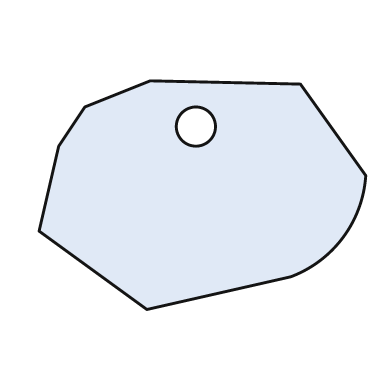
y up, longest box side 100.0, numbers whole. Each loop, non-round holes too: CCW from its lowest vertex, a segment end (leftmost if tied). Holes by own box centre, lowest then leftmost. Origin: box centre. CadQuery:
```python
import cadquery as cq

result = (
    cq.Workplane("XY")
    .moveTo(-17.0, -35.0)
    .lineTo(27.0, -25.0)
    .threePointArc((43.0, -13.0), (50.0, 6.0))
    .lineTo(30.0, 34.0)
    .lineTo(-16.0, 35.0)
    .lineTo(-36.0, 27.0)
    .lineTo(-44.0, 15.0)
    .lineTo(-50.0, -11.0)
    .close()
    .moveTo(-2.0, 21.0)
    .circle(6.0)
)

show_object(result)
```